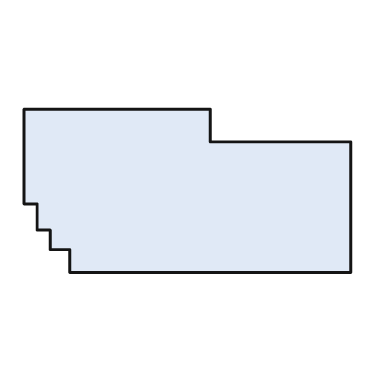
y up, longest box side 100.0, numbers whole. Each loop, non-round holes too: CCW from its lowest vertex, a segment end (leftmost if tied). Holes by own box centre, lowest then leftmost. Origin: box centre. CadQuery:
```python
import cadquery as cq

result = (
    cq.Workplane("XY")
    .moveTo(-36.0, -25.0)
    .lineTo(50.0, -25.0)
    .lineTo(50.0, 15.0)
    .lineTo(7.0, 15.0)
    .lineTo(7.0, 25.0)
    .lineTo(-50.0, 25.0)
    .lineTo(-50.0, -4.0)
    .lineTo(-46.0, -4.0)
    .lineTo(-46.0, -12.0)
    .lineTo(-42.0, -12.0)
    .lineTo(-42.0, -18.0)
    .lineTo(-36.0, -18.0)
    .close()
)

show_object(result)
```